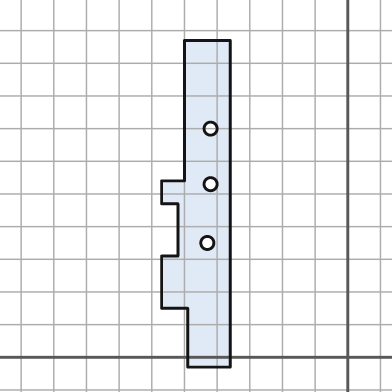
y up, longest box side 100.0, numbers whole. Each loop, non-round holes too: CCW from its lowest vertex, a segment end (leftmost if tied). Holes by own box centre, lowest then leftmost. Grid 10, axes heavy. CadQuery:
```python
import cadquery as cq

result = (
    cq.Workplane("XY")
    .moveTo(-49.0, -3.0)
    .lineTo(-36.0, -3.0)
    .lineTo(-36.0, 97.0)
    .lineTo(-50.0, 97.0)
    .lineTo(-50.0, 54.0)
    .lineTo(-57.0, 54.0)
    .lineTo(-57.0, 47.0)
    .lineTo(-52.0, 47.0)
    .lineTo(-52.0, 31.0)
    .lineTo(-57.0, 31.0)
    .lineTo(-57.0, 15.0)
    .lineTo(-49.0, 15.0)
    .close()
    .moveTo(-43.0, 35.0)
    .circle(2.0)
    .moveTo(-42.0, 53.0)
    .circle(2.0)
    .moveTo(-42.0, 70.0)
    .circle(2.0)
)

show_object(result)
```